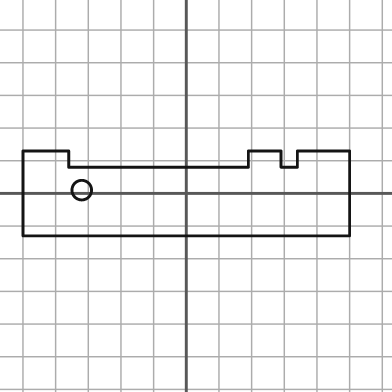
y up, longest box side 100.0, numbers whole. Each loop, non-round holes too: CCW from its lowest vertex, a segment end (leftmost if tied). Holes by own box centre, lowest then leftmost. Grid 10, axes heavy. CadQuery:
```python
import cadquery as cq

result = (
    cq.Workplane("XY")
    .moveTo(-50.0, -13.0)
    .lineTo(50.0, -13.0)
    .lineTo(50.0, 13.0)
    .lineTo(34.0, 13.0)
    .lineTo(34.0, 8.0)
    .lineTo(29.0, 8.0)
    .lineTo(29.0, 13.0)
    .lineTo(19.0, 13.0)
    .lineTo(19.0, 8.0)
    .lineTo(-36.0, 8.0)
    .lineTo(-36.0, 13.0)
    .lineTo(-50.0, 13.0)
    .close()
    .moveTo(-32.0, 1.0)
    .circle(3.0)
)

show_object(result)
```